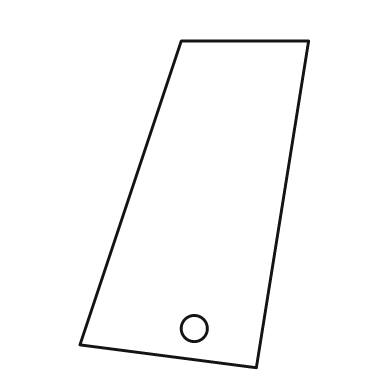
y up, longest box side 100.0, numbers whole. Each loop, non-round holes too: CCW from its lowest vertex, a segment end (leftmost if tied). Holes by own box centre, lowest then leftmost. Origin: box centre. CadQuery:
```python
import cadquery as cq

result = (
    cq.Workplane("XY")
    .moveTo(19.0, -50.0)
    .lineTo(35.0, 50.0)
    .lineTo(-4.0, 50.0)
    .lineTo(-35.0, -43.0)
    .close()
    .moveTo(0.0, -38.0)
    .circle(4.0)
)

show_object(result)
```